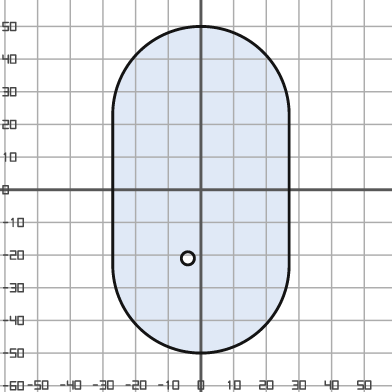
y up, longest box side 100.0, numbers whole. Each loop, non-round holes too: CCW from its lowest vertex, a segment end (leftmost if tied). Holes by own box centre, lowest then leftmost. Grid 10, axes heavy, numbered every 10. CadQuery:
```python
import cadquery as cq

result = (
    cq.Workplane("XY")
    .moveTo(-27.0, -23.0)
    .threePointArc((0.0, -50.0), (27.0, -23.0))
    .lineTo(27.0, 23.0)
    .threePointArc((0.0, 50.0), (-27.0, 23.0))
    .close()
    .moveTo(-4.0, -21.0)
    .circle(2.0)
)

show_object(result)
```